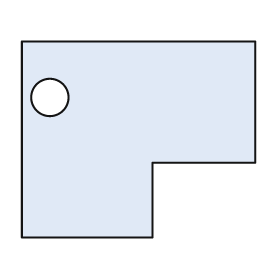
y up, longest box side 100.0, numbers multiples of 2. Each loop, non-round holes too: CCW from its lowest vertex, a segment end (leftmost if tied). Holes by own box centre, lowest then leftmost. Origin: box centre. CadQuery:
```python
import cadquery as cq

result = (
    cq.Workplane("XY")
    .moveTo(-50.0, -42.0)
    .lineTo(6.0, -42.0)
    .lineTo(6.0, -10.0)
    .lineTo(50.0, -10.0)
    .lineTo(50.0, 42.0)
    .lineTo(-50.0, 42.0)
    .close()
    .moveTo(-38.0, 18.0)
    .circle(8.0)
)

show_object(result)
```